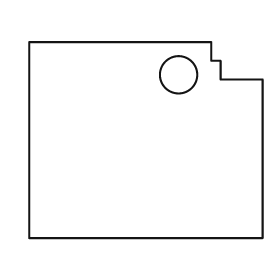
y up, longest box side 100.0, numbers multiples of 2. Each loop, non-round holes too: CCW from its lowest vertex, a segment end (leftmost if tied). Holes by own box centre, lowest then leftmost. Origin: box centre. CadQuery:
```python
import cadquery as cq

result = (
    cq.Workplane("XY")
    .moveTo(-50.0, -42.0)
    .lineTo(50.0, -42.0)
    .lineTo(50.0, 26.0)
    .lineTo(32.0, 26.0)
    .lineTo(32.0, 34.0)
    .lineTo(28.0, 34.0)
    .lineTo(28.0, 42.0)
    .lineTo(-50.0, 42.0)
    .close()
    .moveTo(14.0, 28.0)
    .circle(8.0)
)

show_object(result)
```